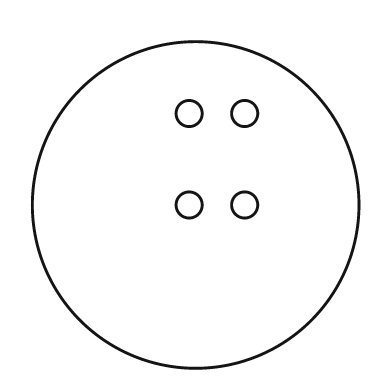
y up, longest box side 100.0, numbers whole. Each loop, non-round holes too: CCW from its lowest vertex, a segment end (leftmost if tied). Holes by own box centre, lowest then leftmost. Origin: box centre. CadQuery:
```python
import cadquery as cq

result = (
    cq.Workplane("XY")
    .moveTo(0.0, 0.0)
    .circle(50.0)
    .moveTo(-2.0, 0.0)
    .circle(4.0)
    .moveTo(15.0, 0.0)
    .circle(4.0)
    .moveTo(-2.0, 28.0)
    .circle(4.0)
    .moveTo(15.0, 28.0)
    .circle(4.0)
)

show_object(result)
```